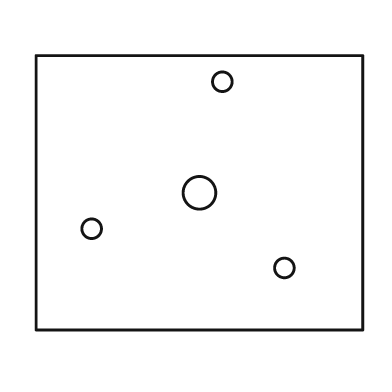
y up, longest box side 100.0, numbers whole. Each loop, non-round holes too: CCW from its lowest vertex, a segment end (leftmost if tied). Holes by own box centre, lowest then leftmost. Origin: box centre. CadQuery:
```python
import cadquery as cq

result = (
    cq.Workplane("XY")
    .moveTo(-50.0, -42.0)
    .lineTo(50.0, -42.0)
    .lineTo(50.0, 42.0)
    .lineTo(-50.0, 42.0)
    .close()
    .moveTo(26.0, -23.0)
    .circle(3.0)
    .moveTo(-33.0, -11.0)
    .circle(3.0)
    .moveTo(0.0, 0.0)
    .circle(5.0)
    .moveTo(7.0, 34.0)
    .circle(3.0)
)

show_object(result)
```